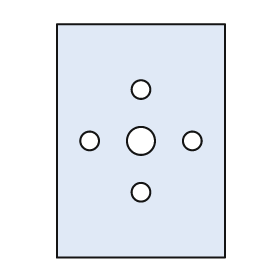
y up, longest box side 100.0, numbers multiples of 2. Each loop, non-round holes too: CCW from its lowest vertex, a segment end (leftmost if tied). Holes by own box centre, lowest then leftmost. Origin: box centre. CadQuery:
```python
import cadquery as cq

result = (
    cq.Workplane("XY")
    .moveTo(-36.0, -50.0)
    .lineTo(36.0, -50.0)
    .lineTo(36.0, 50.0)
    .lineTo(-36.0, 50.0)
    .close()
    .moveTo(0.0, -22.0)
    .circle(4.0)
    .moveTo(-22.0, 0.0)
    .circle(4.0)
    .moveTo(0.0, 0.0)
    .circle(6.0)
    .moveTo(22.0, 0.0)
    .circle(4.0)
    .moveTo(0.0, 22.0)
    .circle(4.0)
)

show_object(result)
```